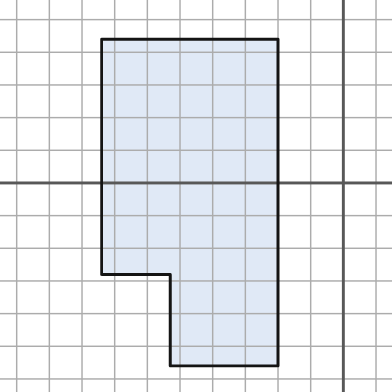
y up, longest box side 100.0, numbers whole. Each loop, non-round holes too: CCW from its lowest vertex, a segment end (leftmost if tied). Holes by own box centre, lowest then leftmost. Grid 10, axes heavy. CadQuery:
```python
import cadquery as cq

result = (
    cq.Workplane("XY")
    .moveTo(-53.0, -56.0)
    .lineTo(-20.0, -56.0)
    .lineTo(-20.0, 44.0)
    .lineTo(-74.0, 44.0)
    .lineTo(-74.0, -28.0)
    .lineTo(-53.0, -28.0)
    .close()
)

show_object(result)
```